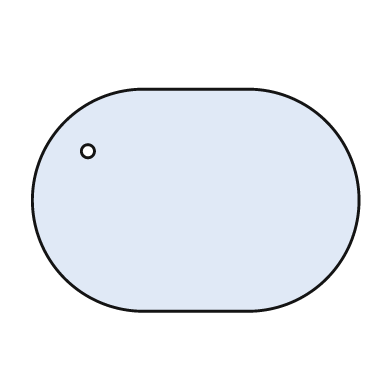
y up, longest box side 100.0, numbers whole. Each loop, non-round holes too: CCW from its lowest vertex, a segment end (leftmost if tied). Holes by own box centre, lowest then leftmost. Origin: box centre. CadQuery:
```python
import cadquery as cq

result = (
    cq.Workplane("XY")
    .moveTo(-16.0, -34.0)
    .lineTo(16.0, -34.0)
    .threePointArc((50.0, 0.0), (16.0, 34.0))
    .lineTo(-16.0, 34.0)
    .threePointArc((-50.0, 0.0), (-16.0, -34.0))
    .close()
    .moveTo(-33.0, 15.0)
    .circle(2.0)
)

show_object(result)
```